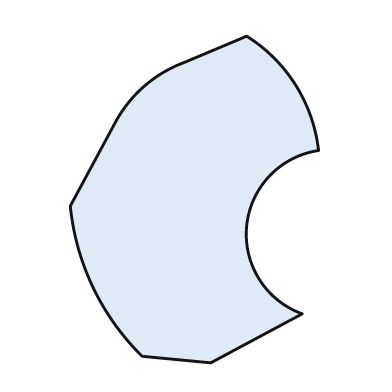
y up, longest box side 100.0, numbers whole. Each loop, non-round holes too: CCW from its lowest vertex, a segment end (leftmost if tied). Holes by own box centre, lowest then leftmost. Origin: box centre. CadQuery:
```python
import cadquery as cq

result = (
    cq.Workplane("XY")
    .moveTo(5.0, -50.0)
    .lineTo(33.0, -35.0)
    .threePointArc((16.0, -8.0), (38.0, 15.0))
    .threePointArc((31.0, 35.0), (16.0, 50.0))
    .lineTo(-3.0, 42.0)
    .threePointArc((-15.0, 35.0), (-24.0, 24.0))
    .lineTo(-38.0, -2.0)
    .threePointArc((-31.0, -27.0), (-16.0, -48.0))
    .close()
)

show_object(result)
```